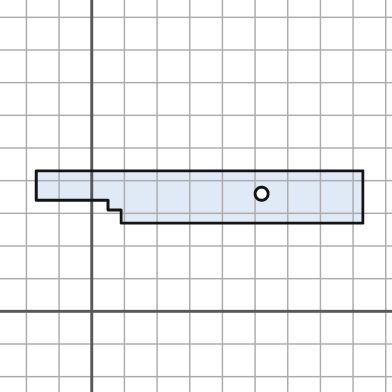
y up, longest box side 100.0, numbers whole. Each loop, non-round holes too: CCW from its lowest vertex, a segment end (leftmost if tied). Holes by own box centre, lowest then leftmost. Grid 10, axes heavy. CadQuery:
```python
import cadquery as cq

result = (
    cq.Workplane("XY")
    .moveTo(9.0, 27.0)
    .lineTo(83.0, 27.0)
    .lineTo(83.0, 43.0)
    .lineTo(-17.0, 43.0)
    .lineTo(-17.0, 34.0)
    .lineTo(5.0, 34.0)
    .lineTo(5.0, 31.0)
    .lineTo(9.0, 31.0)
    .close()
    .moveTo(52.0, 36.0)
    .circle(2.0)
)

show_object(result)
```